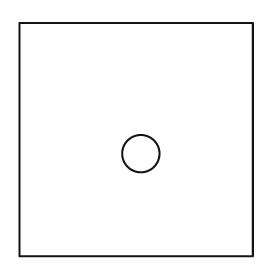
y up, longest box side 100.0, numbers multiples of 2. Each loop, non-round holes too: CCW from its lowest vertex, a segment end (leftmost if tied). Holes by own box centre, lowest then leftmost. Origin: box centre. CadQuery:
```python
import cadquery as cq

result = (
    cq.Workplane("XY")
    .moveTo(-50.0, -50.0)
    .lineTo(50.0, -50.0)
    .lineTo(50.0, 50.0)
    .lineTo(-50.0, 50.0)
    .close()
    .moveTo(2.0, -6.0)
    .circle(8.0)
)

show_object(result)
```